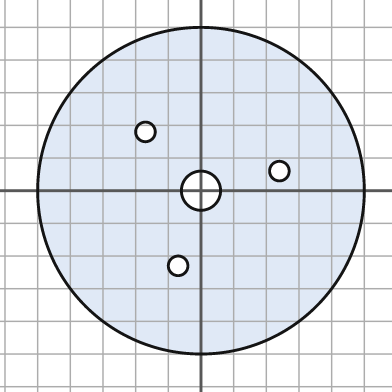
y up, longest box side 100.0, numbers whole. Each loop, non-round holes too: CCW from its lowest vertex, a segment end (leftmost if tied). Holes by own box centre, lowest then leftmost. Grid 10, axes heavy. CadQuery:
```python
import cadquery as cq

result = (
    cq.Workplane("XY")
    .moveTo(0.0, 0.0)
    .circle(50.0)
    .moveTo(-7.0, -23.0)
    .circle(3.0)
    .moveTo(0.0, 0.0)
    .circle(6.0)
    .moveTo(24.0, 6.0)
    .circle(3.0)
    .moveTo(-17.0, 18.0)
    .circle(3.0)
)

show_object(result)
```